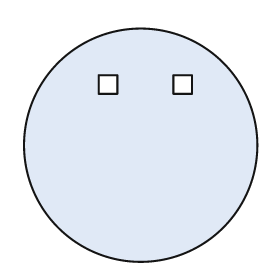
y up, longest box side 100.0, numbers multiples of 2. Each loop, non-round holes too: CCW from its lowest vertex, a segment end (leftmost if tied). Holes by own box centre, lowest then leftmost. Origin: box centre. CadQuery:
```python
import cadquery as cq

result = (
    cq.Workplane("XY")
    .moveTo(0.0, 0.0)
    .circle(50.0)
    .moveTo(-18.0, 22.0)
    .lineTo(-10.0, 22.0)
    .lineTo(-10.0, 30.0)
    .lineTo(-18.0, 30.0)
    .close()
    .moveTo(14.0, 22.0)
    .lineTo(22.0, 22.0)
    .lineTo(22.0, 30.0)
    .lineTo(14.0, 30.0)
    .close()
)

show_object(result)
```